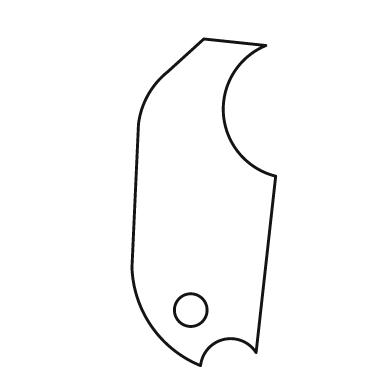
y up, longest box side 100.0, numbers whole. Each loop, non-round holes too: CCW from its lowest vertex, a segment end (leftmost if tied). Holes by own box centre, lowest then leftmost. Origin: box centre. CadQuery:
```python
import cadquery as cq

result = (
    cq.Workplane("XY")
    .moveTo(-1.0, -50.0)
    .threePointArc((6.0, -42.0), (16.0, -46.0))
    .lineTo(22.0, 8.0)
    .threePointArc((6.0, 27.0), (19.0, 48.0))
    .lineTo(0.0, 50.0)
    .lineTo(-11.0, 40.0)
    .threePointArc((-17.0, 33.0), (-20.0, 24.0))
    .lineTo(-22.0, -20.0)
    .threePointArc((-16.0, -38.0), (-1.0, -50.0))
    .close()
    .moveTo(-4.0, -33.0)
    .circle(5.0)
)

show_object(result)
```